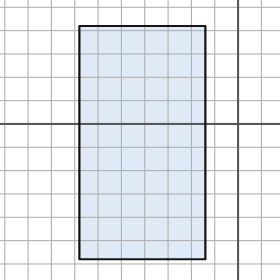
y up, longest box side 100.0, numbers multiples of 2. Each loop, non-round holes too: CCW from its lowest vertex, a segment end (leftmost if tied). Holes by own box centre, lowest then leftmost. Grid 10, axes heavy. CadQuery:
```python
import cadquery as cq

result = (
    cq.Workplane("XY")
    .moveTo(-68.0, -58.0)
    .lineTo(-14.0, -58.0)
    .lineTo(-14.0, 42.0)
    .lineTo(-68.0, 42.0)
    .close()
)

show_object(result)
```